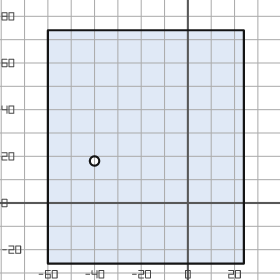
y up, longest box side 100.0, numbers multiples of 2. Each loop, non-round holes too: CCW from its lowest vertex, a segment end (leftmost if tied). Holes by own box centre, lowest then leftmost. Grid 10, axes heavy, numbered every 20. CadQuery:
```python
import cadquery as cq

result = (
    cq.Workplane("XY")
    .moveTo(-60.0, -26.0)
    .lineTo(24.0, -26.0)
    .lineTo(24.0, 74.0)
    .lineTo(-60.0, 74.0)
    .close()
    .moveTo(-40.0, 18.0)
    .circle(2.0)
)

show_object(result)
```